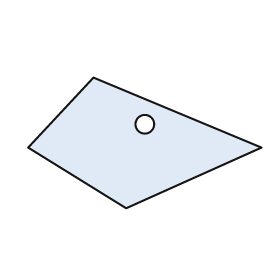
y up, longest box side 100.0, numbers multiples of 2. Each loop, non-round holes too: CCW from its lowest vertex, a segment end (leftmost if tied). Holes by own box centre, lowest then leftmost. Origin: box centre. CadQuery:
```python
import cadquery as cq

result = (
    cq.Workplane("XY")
    .moveTo(-8.0, -28.0)
    .lineTo(50.0, -2.0)
    .lineTo(-22.0, 28.0)
    .lineTo(-50.0, -2.0)
    .close()
    .moveTo(0.0, 8.0)
    .circle(4.0)
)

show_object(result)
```